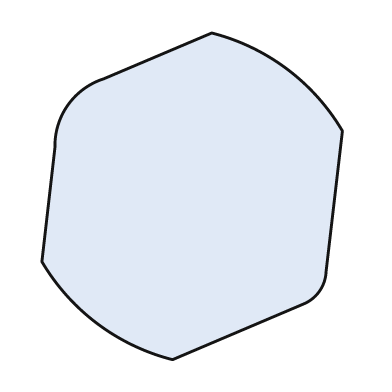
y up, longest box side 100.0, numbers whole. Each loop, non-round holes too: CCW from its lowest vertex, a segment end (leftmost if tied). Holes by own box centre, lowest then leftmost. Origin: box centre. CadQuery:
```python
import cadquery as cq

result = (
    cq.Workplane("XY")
    .moveTo(-6.0, -50.0)
    .lineTo(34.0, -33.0)
    .threePointArc((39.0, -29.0), (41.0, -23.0))
    .lineTo(46.0, 20.0)
    .threePointArc((29.0, 39.0), (6.0, 50.0))
    .lineTo(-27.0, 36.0)
    .threePointArc((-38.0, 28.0), (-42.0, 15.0))
    .lineTo(-46.0, -20.0)
    .threePointArc((-29.0, -39.0), (-6.0, -50.0))
    .close()
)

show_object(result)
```